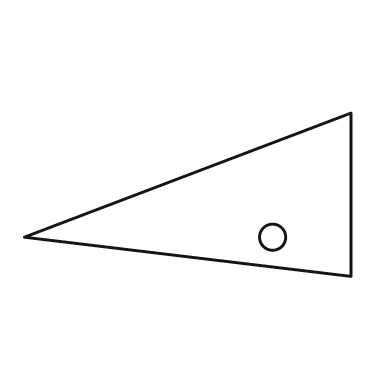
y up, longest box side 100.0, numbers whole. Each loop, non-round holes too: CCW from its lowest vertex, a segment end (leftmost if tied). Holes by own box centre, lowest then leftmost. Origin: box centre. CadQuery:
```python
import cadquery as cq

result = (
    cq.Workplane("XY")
    .moveTo(50.0, -25.0)
    .lineTo(50.0, 25.0)
    .lineTo(-50.0, -13.0)
    .close()
    .moveTo(26.0, -13.0)
    .circle(4.0)
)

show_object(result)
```